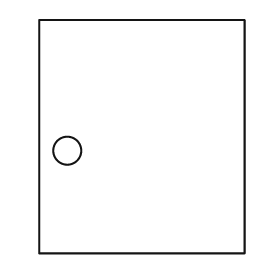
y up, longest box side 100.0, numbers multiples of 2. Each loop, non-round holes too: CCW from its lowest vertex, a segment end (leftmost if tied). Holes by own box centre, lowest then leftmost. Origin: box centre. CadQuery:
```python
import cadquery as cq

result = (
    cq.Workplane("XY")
    .moveTo(-44.0, -50.0)
    .lineTo(44.0, -50.0)
    .lineTo(44.0, 50.0)
    .lineTo(-44.0, 50.0)
    .close()
    .moveTo(-32.0, -6.0)
    .circle(6.0)
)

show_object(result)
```